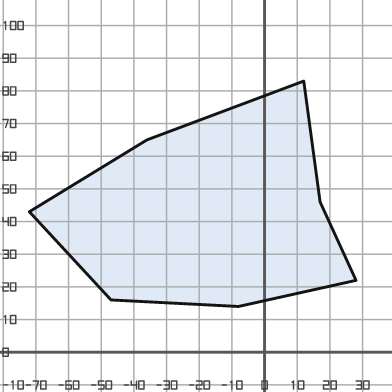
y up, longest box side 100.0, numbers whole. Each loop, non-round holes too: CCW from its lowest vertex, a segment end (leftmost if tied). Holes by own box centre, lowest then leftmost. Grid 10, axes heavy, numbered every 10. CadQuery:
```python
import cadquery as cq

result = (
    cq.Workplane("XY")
    .moveTo(-8.0, 14.0)
    .lineTo(28.0, 22.0)
    .lineTo(17.0, 46.0)
    .lineTo(12.0, 83.0)
    .lineTo(-36.0, 65.0)
    .lineTo(-72.0, 43.0)
    .lineTo(-47.0, 16.0)
    .close()
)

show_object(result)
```